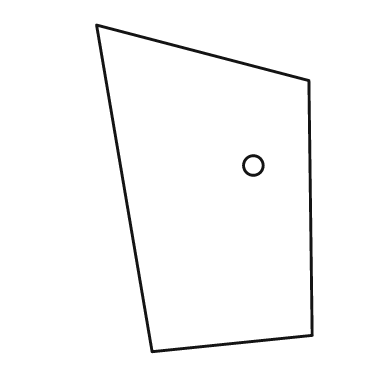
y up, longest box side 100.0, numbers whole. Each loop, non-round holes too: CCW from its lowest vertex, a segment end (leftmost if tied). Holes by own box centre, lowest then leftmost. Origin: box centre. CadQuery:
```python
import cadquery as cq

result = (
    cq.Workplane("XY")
    .moveTo(-16.0, -50.0)
    .lineTo(33.0, -45.0)
    .lineTo(32.0, 33.0)
    .lineTo(-33.0, 50.0)
    .close()
    .moveTo(15.0, 7.0)
    .circle(3.0)
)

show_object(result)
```